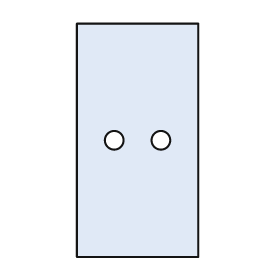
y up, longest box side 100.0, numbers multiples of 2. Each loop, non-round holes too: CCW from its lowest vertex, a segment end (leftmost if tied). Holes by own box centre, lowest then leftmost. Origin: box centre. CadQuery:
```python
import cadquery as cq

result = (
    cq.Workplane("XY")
    .moveTo(-26.0, -50.0)
    .lineTo(26.0, -50.0)
    .lineTo(26.0, 50.0)
    .lineTo(-26.0, 50.0)
    .close()
    .moveTo(-10.0, 0.0)
    .circle(4.0)
    .moveTo(10.0, 0.0)
    .circle(4.0)
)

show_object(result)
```